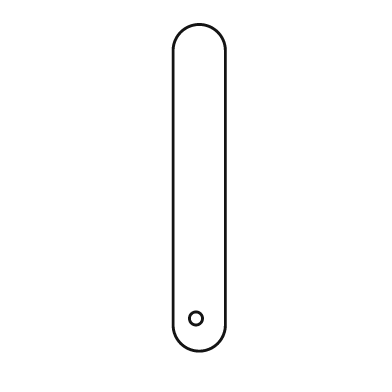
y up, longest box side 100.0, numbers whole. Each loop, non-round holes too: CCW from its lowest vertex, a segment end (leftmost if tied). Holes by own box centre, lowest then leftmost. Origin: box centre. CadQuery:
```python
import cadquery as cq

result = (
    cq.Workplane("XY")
    .moveTo(-8.0, -42.0)
    .threePointArc((0.0, -50.0), (8.0, -42.0))
    .lineTo(8.0, 42.0)
    .threePointArc((0.0, 50.0), (-8.0, 42.0))
    .close()
    .moveTo(-1.0, -40.0)
    .circle(2.0)
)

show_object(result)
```